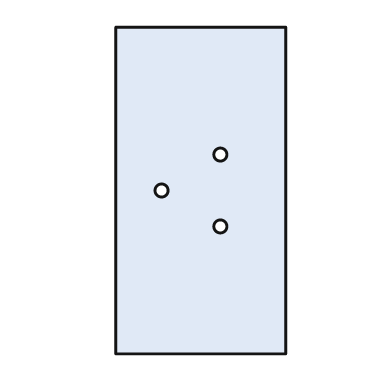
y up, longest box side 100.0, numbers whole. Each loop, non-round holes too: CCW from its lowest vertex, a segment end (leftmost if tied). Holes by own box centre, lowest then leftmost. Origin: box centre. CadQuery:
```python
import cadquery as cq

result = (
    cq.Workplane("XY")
    .moveTo(-26.0, -50.0)
    .lineTo(26.0, -50.0)
    .lineTo(26.0, 50.0)
    .lineTo(-26.0, 50.0)
    .close()
    .moveTo(6.0, -11.0)
    .circle(2.0)
    .moveTo(-12.0, 0.0)
    .circle(2.0)
    .moveTo(6.0, 11.0)
    .circle(2.0)
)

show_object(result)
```